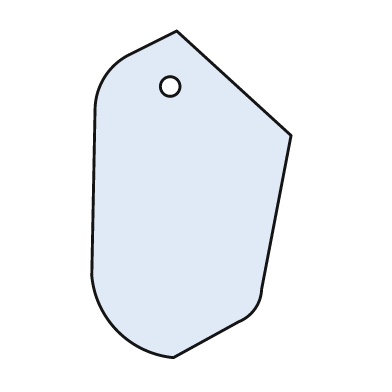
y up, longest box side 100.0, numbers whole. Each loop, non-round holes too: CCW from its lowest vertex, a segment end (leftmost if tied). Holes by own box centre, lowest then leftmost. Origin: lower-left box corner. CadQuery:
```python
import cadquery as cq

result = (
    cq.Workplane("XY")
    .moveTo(25.0, 0.0)
    .lineTo(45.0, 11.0)
    .threePointArc((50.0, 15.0), (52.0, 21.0))
    .lineTo(61.0, 68.0)
    .lineTo(26.0, 100.0)
    .lineTo(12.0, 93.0)
    .threePointArc((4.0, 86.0), (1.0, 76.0))
    .lineTo(0.0, 25.0)
    .threePointArc((8.0, 8.0), (25.0, 0.0))
    .close()
    .moveTo(24.0, 83.0)
    .circle(3.0)
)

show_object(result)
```